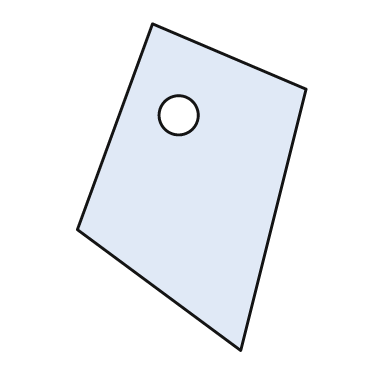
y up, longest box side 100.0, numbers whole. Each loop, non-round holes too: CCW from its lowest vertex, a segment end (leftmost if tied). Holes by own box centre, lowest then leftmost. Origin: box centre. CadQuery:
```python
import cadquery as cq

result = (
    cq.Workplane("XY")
    .moveTo(15.0, -50.0)
    .lineTo(35.0, 30.0)
    .lineTo(-12.0, 50.0)
    .lineTo(-35.0, -13.0)
    .close()
    .moveTo(-4.0, 22.0)
    .circle(6.0)
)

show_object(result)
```